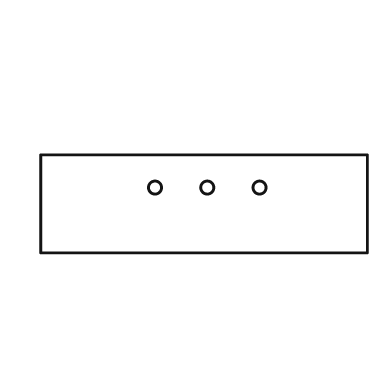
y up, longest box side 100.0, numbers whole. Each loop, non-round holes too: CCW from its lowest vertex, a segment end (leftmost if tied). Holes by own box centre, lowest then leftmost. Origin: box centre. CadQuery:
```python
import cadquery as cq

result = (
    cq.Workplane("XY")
    .moveTo(-50.0, -15.0)
    .lineTo(50.0, -15.0)
    .lineTo(50.0, 15.0)
    .lineTo(-50.0, 15.0)
    .close()
    .moveTo(-15.0, 5.0)
    .circle(2.0)
    .moveTo(1.0, 5.0)
    .circle(2.0)
    .moveTo(17.0, 5.0)
    .circle(2.0)
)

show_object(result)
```